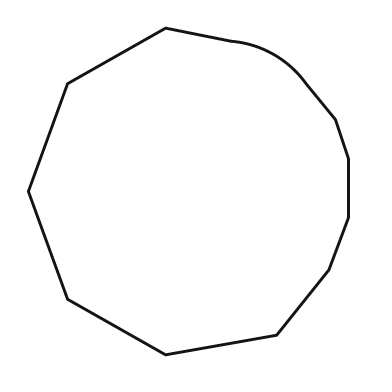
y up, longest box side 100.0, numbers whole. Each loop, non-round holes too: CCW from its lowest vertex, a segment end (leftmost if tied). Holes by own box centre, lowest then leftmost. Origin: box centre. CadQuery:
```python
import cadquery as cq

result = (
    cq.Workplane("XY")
    .moveTo(-7.0, -50.0)
    .lineTo(27.0, -44.0)
    .lineTo(43.0, -24.0)
    .lineTo(49.0, -8.0)
    .lineTo(49.0, 10.0)
    .lineTo(45.0, 22.0)
    .lineTo(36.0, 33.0)
    .threePointArc((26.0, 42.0), (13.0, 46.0))
    .lineTo(-7.0, 50.0)
    .lineTo(-37.0, 33.0)
    .lineTo(-49.0, 0.0)
    .lineTo(-37.0, -33.0)
    .close()
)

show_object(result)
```